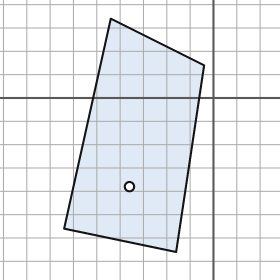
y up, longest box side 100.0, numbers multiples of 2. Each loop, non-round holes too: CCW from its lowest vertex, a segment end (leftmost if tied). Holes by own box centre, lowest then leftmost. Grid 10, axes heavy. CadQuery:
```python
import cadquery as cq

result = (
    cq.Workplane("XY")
    .moveTo(-16.0, -66.0)
    .lineTo(-4.0, 14.0)
    .lineTo(-44.0, 34.0)
    .lineTo(-64.0, -56.0)
    .close()
    .moveTo(-36.0, -38.0)
    .circle(2.0)
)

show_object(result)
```